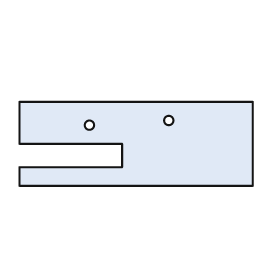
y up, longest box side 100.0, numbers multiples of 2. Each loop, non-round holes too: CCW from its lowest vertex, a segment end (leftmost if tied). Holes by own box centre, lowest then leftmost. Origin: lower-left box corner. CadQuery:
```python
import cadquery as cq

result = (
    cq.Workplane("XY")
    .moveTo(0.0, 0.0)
    .lineTo(100.0, 0.0)
    .lineTo(100.0, 36.0)
    .lineTo(0.0, 36.0)
    .lineTo(0.0, 18.0)
    .lineTo(44.0, 18.0)
    .lineTo(44.0, 8.0)
    .lineTo(0.0, 8.0)
    .close()
    .moveTo(30.0, 26.0)
    .circle(2.0)
    .moveTo(64.0, 28.0)
    .circle(2.0)
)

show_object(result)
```